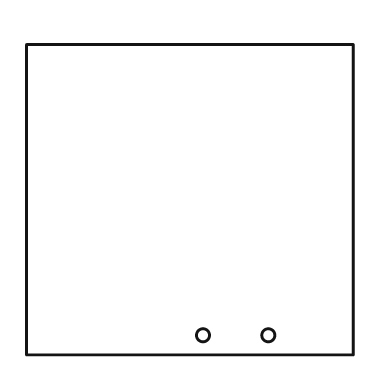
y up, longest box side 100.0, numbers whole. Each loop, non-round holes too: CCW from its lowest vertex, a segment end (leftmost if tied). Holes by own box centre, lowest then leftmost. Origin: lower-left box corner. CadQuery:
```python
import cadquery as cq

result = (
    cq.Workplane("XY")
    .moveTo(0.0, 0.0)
    .lineTo(100.0, 0.0)
    .lineTo(100.0, 95.0)
    .lineTo(0.0, 95.0)
    .close()
    .moveTo(54.0, 6.0)
    .circle(2.0)
    .moveTo(74.0, 6.0)
    .circle(2.0)
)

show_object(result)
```